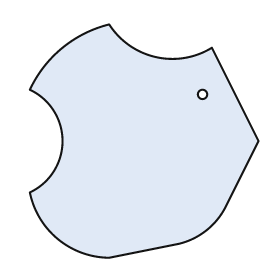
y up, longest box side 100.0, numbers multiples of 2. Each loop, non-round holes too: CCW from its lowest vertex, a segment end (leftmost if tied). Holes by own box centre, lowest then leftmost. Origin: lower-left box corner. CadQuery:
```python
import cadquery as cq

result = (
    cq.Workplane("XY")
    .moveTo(34.0, 0.0)
    .lineTo(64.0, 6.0)
    .threePointArc((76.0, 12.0), (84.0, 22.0))
    .lineTo(98.0, 50.0)
    .lineTo(78.0, 90.0)
    .threePointArc((54.0, 86.0), (34.0, 100.0))
    .threePointArc((14.0, 90.0), (0.0, 72.0))
    .threePointArc((14.0, 50.0), (0.0, 28.0))
    .threePointArc((12.0, 8.0), (34.0, 0.0))
    .close()
    .moveTo(74.0, 70.0)
    .circle(2.0)
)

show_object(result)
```